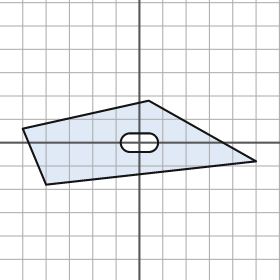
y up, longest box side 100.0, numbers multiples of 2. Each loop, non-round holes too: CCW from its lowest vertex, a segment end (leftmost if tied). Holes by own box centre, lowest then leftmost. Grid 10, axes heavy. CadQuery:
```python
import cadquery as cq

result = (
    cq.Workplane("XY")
    .moveTo(-40.0, -18.0)
    .lineTo(50.0, -8.0)
    .lineTo(4.0, 18.0)
    .lineTo(-50.0, 6.0)
    .close()
    .moveTo(-4.0, -4.0)
    .lineTo(4.0, -4.0)
    .threePointArc((8.0, 0.0), (4.0, 4.0))
    .lineTo(-4.0, 4.0)
    .threePointArc((-8.0, 0.0), (-4.0, -4.0))
    .close()
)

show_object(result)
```